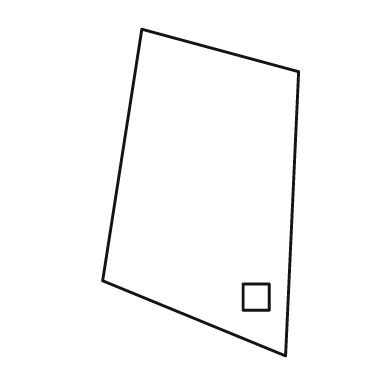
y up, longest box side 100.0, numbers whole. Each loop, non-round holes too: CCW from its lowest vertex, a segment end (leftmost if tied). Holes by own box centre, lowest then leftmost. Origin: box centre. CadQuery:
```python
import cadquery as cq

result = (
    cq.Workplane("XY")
    .moveTo(26.0, -50.0)
    .lineTo(30.0, 37.0)
    .lineTo(-18.0, 50.0)
    .lineTo(-30.0, -27.0)
    .close()
    .moveTo(13.0, -36.0)
    .lineTo(21.0, -36.0)
    .lineTo(21.0, -28.0)
    .lineTo(13.0, -28.0)
    .close()
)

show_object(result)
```